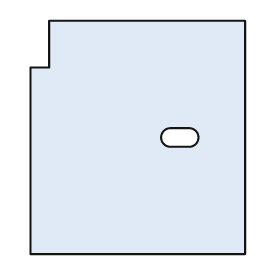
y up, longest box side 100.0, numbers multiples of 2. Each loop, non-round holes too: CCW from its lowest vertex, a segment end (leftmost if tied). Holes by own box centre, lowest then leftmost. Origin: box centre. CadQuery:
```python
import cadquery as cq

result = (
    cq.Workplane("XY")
    .moveTo(-46.0, -50.0)
    .lineTo(46.0, -50.0)
    .lineTo(46.0, 50.0)
    .lineTo(-38.0, 50.0)
    .lineTo(-38.0, 30.0)
    .lineTo(-46.0, 30.0)
    .close()
    .moveTo(14.0, -4.0)
    .lineTo(22.0, -4.0)
    .threePointArc((26.0, 0.0), (22.0, 4.0))
    .lineTo(14.0, 4.0)
    .threePointArc((10.0, 0.0), (14.0, -4.0))
    .close()
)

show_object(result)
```